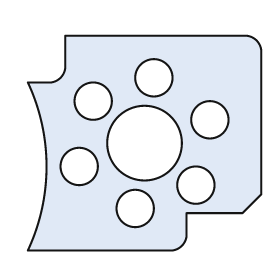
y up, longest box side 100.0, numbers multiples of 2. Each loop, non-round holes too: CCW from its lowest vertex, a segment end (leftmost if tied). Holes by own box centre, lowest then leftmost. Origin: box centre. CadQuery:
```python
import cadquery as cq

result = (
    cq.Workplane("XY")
    .moveTo(-50.0, -46.0)
    .lineTo(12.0, -46.0)
    .threePointArc((16.0, -44.0), (18.0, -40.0))
    .lineTo(18.0, -30.0)
    .lineTo(42.0, -30.0)
    .lineTo(50.0, -22.0)
    .lineTo(50.0, 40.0)
    .threePointArc((48.0, 44.0), (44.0, 46.0))
    .lineTo(-34.0, 46.0)
    .lineTo(-34.0, 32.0)
    .threePointArc((-36.0, 28.0), (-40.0, 26.0))
    .lineTo(-50.0, 26.0)
    .threePointArc((-42.0, -10.0), (-50.0, -46.0))
    .close()
    .moveTo(-4.0, -28.0)
    .circle(8.0)
    .moveTo(22.0, -18.0)
    .circle(8.0)
    .moveTo(-28.0, -10.0)
    .circle(8.0)
    .moveTo(0.0, 0.0)
    .circle(16.0)
    .moveTo(28.0, 10.0)
    .circle(8.0)
    .moveTo(-22.0, 18.0)
    .circle(8.0)
    .moveTo(4.0, 28.0)
    .circle(8.0)
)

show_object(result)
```